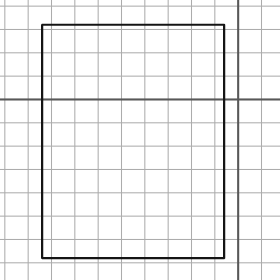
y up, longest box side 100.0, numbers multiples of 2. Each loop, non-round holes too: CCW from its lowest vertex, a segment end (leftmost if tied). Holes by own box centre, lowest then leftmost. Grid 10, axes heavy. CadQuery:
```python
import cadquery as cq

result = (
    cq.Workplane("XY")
    .moveTo(-84.0, -68.0)
    .lineTo(-6.0, -68.0)
    .lineTo(-6.0, 32.0)
    .lineTo(-84.0, 32.0)
    .close()
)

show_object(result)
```